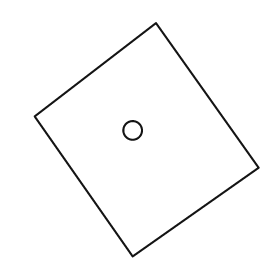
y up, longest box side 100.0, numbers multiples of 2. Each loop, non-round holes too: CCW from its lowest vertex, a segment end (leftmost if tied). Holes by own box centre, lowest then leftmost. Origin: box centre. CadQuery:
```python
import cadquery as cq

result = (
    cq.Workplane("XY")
    .moveTo(-6.0, -50.0)
    .lineTo(48.0, -12.0)
    .lineTo(4.0, 50.0)
    .lineTo(-48.0, 10.0)
    .close()
    .moveTo(-6.0, 4.0)
    .circle(4.0)
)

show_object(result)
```